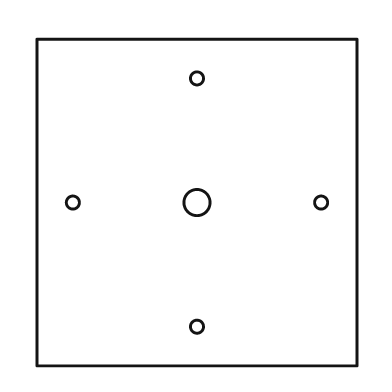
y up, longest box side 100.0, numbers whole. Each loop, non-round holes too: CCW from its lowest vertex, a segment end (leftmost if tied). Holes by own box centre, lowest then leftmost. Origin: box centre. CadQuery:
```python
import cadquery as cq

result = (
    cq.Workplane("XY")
    .moveTo(-49.0, -50.0)
    .lineTo(49.0, -50.0)
    .lineTo(49.0, 50.0)
    .lineTo(-49.0, 50.0)
    .close()
    .moveTo(0.0, -38.0)
    .circle(2.0)
    .moveTo(-38.0, 0.0)
    .circle(2.0)
    .moveTo(0.0, 0.0)
    .circle(4.0)
    .moveTo(38.0, 0.0)
    .circle(2.0)
    .moveTo(0.0, 38.0)
    .circle(2.0)
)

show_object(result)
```